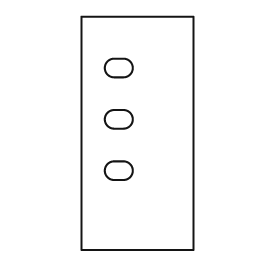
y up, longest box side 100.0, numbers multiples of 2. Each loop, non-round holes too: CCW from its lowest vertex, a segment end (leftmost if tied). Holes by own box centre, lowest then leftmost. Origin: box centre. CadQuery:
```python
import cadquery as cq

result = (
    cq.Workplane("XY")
    .moveTo(-24.0, -50.0)
    .lineTo(24.0, -50.0)
    .lineTo(24.0, 50.0)
    .lineTo(-24.0, 50.0)
    .close()
    .moveTo(-10.0, -20.0)
    .lineTo(-6.0, -20.0)
    .threePointArc((-2.0, -16.0), (-6.0, -12.0))
    .lineTo(-10.0, -12.0)
    .threePointArc((-14.0, -16.0), (-10.0, -20.0))
    .close()
    .moveTo(-10.0, 2.0)
    .lineTo(-6.0, 2.0)
    .threePointArc((-2.0, 6.0), (-6.0, 10.0))
    .lineTo(-10.0, 10.0)
    .threePointArc((-14.0, 6.0), (-10.0, 2.0))
    .close()
    .moveTo(-10.0, 24.0)
    .lineTo(-6.0, 24.0)
    .threePointArc((-2.0, 28.0), (-6.0, 32.0))
    .lineTo(-10.0, 32.0)
    .threePointArc((-14.0, 28.0), (-10.0, 24.0))
    .close()
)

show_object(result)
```